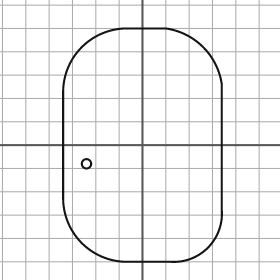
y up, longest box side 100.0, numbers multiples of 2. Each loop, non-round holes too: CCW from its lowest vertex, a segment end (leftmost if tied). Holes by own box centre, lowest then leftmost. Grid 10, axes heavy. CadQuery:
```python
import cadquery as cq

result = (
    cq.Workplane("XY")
    .moveTo(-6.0, -50.0)
    .lineTo(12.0, -50.0)
    .threePointArc((28.0, -44.0), (34.0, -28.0))
    .lineTo(34.0, 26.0)
    .threePointArc((26.0, 42.0), (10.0, 50.0))
    .lineTo(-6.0, 50.0)
    .threePointArc((-26.0, 42.0), (-34.0, 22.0))
    .lineTo(-34.0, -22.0)
    .threePointArc((-26.0, -42.0), (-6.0, -50.0))
    .close()
    .moveTo(-24.0, -8.0)
    .circle(2.0)
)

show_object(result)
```